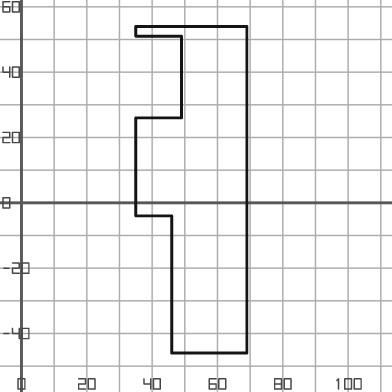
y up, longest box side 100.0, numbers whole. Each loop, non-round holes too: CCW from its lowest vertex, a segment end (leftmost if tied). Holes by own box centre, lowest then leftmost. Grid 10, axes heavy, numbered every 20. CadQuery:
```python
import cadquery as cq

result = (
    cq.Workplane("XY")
    .moveTo(46.0, -46.0)
    .lineTo(69.0, -46.0)
    .lineTo(69.0, 54.0)
    .lineTo(35.0, 54.0)
    .lineTo(35.0, 51.0)
    .lineTo(49.0, 51.0)
    .lineTo(49.0, 26.0)
    .lineTo(35.0, 26.0)
    .lineTo(35.0, -4.0)
    .lineTo(46.0, -4.0)
    .close()
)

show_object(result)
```